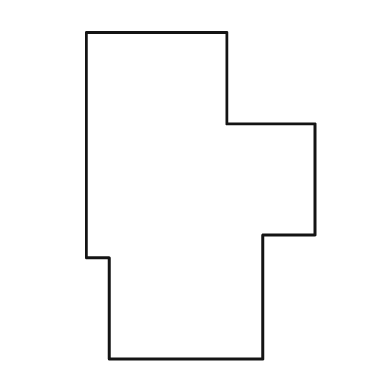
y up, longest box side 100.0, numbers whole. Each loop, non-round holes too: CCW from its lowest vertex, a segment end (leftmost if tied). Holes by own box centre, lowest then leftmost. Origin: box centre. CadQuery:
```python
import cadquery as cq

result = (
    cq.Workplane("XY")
    .moveTo(-28.0, -50.0)
    .lineTo(19.0, -50.0)
    .lineTo(19.0, -12.0)
    .lineTo(35.0, -12.0)
    .lineTo(35.0, 22.0)
    .lineTo(8.0, 22.0)
    .lineTo(8.0, 50.0)
    .lineTo(-35.0, 50.0)
    .lineTo(-35.0, -19.0)
    .lineTo(-28.0, -19.0)
    .close()
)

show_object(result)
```